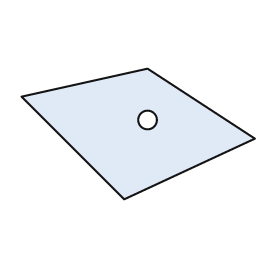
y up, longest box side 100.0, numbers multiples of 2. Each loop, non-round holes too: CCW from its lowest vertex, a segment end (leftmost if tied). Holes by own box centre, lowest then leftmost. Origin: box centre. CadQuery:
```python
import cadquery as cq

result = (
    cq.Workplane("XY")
    .moveTo(-6.0, -28.0)
    .lineTo(50.0, -2.0)
    .lineTo(4.0, 28.0)
    .lineTo(-50.0, 16.0)
    .close()
    .moveTo(4.0, 6.0)
    .circle(4.0)
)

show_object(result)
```